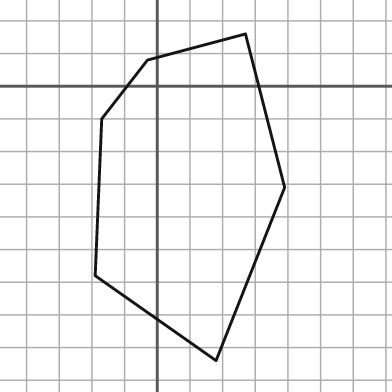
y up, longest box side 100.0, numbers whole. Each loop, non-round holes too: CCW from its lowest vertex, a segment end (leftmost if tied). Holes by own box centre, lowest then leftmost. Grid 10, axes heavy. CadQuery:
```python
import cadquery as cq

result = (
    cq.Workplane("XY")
    .moveTo(18.0, -84.0)
    .lineTo(39.0, -31.0)
    .lineTo(27.0, 16.0)
    .lineTo(-3.0, 8.0)
    .lineTo(-17.0, -10.0)
    .lineTo(-19.0, -58.0)
    .close()
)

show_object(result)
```